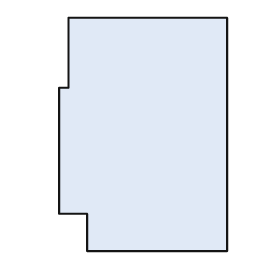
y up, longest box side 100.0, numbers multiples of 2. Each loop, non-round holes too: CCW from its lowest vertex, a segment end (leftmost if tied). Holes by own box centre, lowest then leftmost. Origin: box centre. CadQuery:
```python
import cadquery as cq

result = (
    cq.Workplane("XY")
    .moveTo(-24.0, -50.0)
    .lineTo(36.0, -50.0)
    .lineTo(36.0, 50.0)
    .lineTo(-32.0, 50.0)
    .lineTo(-32.0, 20.0)
    .lineTo(-36.0, 20.0)
    .lineTo(-36.0, -34.0)
    .lineTo(-24.0, -34.0)
    .close()
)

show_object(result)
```